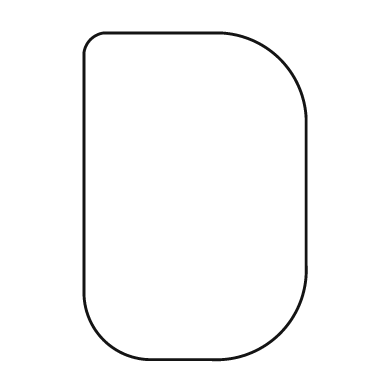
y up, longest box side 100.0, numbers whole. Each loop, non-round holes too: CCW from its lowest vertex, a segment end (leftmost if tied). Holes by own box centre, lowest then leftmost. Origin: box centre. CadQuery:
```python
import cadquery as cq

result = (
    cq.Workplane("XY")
    .moveTo(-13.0, -50.0)
    .lineTo(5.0, -50.0)
    .threePointArc((26.0, -42.0), (34.0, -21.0))
    .lineTo(34.0, 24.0)
    .threePointArc((26.0, 42.0), (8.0, 50.0))
    .lineTo(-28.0, 50.0)
    .threePointArc((-32.0, 48.0), (-34.0, 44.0))
    .lineTo(-34.0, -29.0)
    .threePointArc((-28.0, -44.0), (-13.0, -50.0))
    .close()
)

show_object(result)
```